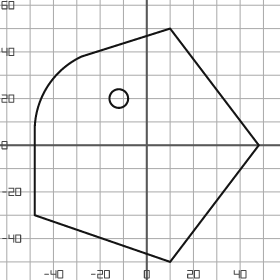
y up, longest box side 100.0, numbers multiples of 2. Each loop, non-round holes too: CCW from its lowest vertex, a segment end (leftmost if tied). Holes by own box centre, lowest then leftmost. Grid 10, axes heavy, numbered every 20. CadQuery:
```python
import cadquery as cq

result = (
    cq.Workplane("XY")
    .moveTo(10.0, -50.0)
    .lineTo(48.0, 0.0)
    .lineTo(10.0, 50.0)
    .lineTo(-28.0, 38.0)
    .threePointArc((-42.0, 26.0), (-48.0, 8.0))
    .lineTo(-48.0, -30.0)
    .close()
    .moveTo(-12.0, 20.0)
    .circle(4.0)
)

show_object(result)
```